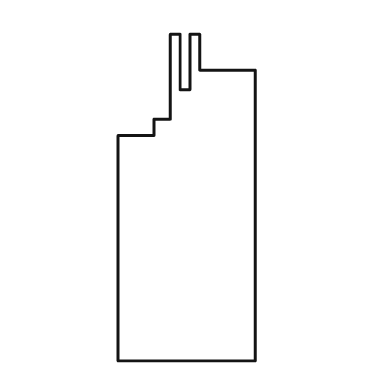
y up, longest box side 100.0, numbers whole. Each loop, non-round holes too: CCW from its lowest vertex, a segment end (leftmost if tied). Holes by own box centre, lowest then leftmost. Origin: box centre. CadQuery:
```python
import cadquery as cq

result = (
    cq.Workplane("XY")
    .moveTo(-21.0, -50.0)
    .lineTo(21.0, -50.0)
    .lineTo(21.0, 39.0)
    .lineTo(4.0, 39.0)
    .lineTo(4.0, 50.0)
    .lineTo(1.0, 50.0)
    .lineTo(1.0, 33.0)
    .lineTo(-2.0, 33.0)
    .lineTo(-2.0, 50.0)
    .lineTo(-5.0, 50.0)
    .lineTo(-5.0, 24.0)
    .lineTo(-10.0, 24.0)
    .lineTo(-10.0, 19.0)
    .lineTo(-21.0, 19.0)
    .close()
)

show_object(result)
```